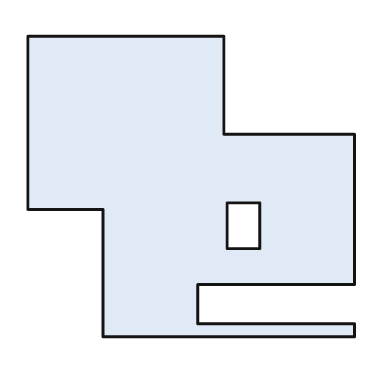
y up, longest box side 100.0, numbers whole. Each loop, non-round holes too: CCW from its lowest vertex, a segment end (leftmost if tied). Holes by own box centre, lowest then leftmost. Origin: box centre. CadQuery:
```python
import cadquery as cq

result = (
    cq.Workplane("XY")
    .moveTo(-27.0, -46.0)
    .lineTo(50.0, -46.0)
    .lineTo(50.0, -42.0)
    .lineTo(2.0, -42.0)
    .lineTo(2.0, -30.0)
    .lineTo(50.0, -30.0)
    .lineTo(50.0, 16.0)
    .lineTo(10.0, 16.0)
    .lineTo(10.0, 46.0)
    .lineTo(-50.0, 46.0)
    .lineTo(-50.0, -7.0)
    .lineTo(-27.0, -7.0)
    .close()
    .moveTo(11.0, -19.0)
    .lineTo(21.0, -19.0)
    .lineTo(21.0, -5.0)
    .lineTo(11.0, -5.0)
    .close()
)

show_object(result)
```